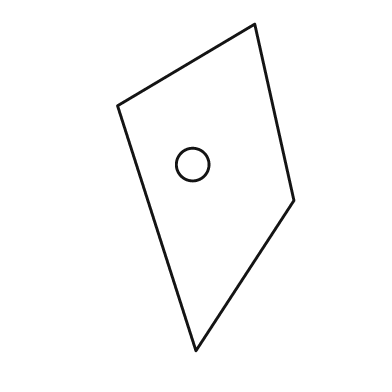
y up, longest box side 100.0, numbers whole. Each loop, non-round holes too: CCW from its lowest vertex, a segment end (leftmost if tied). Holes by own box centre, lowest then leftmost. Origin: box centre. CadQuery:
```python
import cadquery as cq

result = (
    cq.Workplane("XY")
    .moveTo(-3.0, -50.0)
    .lineTo(27.0, -4.0)
    .lineTo(15.0, 50.0)
    .lineTo(-27.0, 25.0)
    .close()
    .moveTo(-4.0, 7.0)
    .circle(5.0)
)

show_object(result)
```